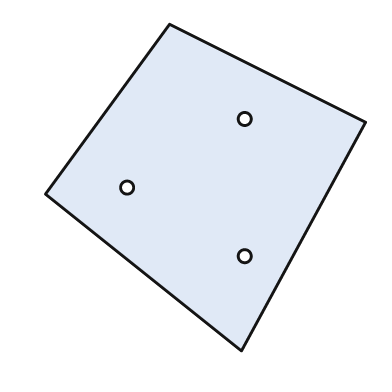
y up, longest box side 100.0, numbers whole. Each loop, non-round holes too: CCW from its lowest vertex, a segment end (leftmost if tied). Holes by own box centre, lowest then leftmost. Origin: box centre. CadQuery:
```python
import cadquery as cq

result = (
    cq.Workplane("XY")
    .moveTo(11.0, -50.0)
    .lineTo(49.0, 20.0)
    .lineTo(-11.0, 50.0)
    .lineTo(-49.0, -2.0)
    .close()
    .moveTo(12.0, -21.0)
    .circle(2.0)
    .moveTo(-24.0, 0.0)
    .circle(2.0)
    .moveTo(12.0, 21.0)
    .circle(2.0)
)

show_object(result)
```